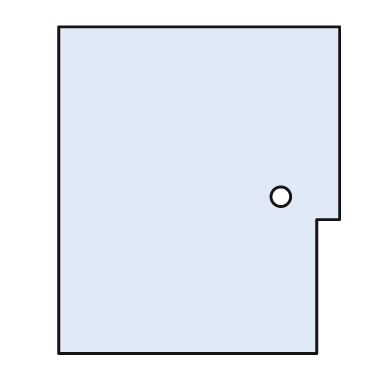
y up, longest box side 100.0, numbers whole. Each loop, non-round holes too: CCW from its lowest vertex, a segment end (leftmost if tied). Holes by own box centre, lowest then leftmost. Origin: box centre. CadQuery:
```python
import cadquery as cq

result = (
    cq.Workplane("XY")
    .moveTo(-43.0, -50.0)
    .lineTo(36.0, -50.0)
    .lineTo(36.0, -9.0)
    .lineTo(43.0, -9.0)
    .lineTo(43.0, 50.0)
    .lineTo(-43.0, 50.0)
    .close()
    .moveTo(25.0, -2.0)
    .circle(3.0)
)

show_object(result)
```